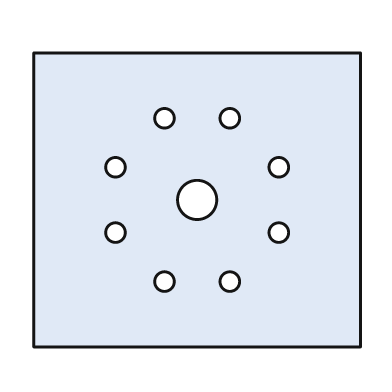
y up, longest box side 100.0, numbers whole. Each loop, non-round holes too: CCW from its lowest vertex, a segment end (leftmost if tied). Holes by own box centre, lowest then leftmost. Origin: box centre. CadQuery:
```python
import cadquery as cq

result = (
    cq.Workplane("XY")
    .moveTo(-50.0, -45.0)
    .lineTo(50.0, -45.0)
    .lineTo(50.0, 45.0)
    .lineTo(-50.0, 45.0)
    .close()
    .moveTo(-10.0, -25.0)
    .circle(3.0)
    .moveTo(10.0, -25.0)
    .circle(3.0)
    .moveTo(-25.0, -10.0)
    .circle(3.0)
    .moveTo(25.0, -10.0)
    .circle(3.0)
    .moveTo(0.0, 0.0)
    .circle(6.0)
    .moveTo(-25.0, 10.0)
    .circle(3.0)
    .moveTo(25.0, 10.0)
    .circle(3.0)
    .moveTo(-10.0, 25.0)
    .circle(3.0)
    .moveTo(10.0, 25.0)
    .circle(3.0)
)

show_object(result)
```